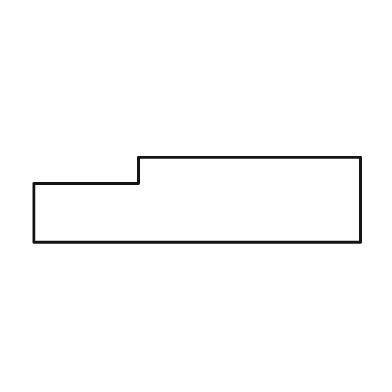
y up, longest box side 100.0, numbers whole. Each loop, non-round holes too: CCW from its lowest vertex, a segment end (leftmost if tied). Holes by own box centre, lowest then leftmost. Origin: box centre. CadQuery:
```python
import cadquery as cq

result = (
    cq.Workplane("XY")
    .moveTo(-50.0, -13.0)
    .lineTo(50.0, -13.0)
    .lineTo(50.0, 13.0)
    .lineTo(-18.0, 13.0)
    .lineTo(-18.0, 5.0)
    .lineTo(-50.0, 5.0)
    .close()
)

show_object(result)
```